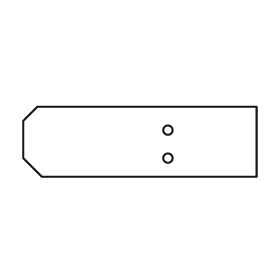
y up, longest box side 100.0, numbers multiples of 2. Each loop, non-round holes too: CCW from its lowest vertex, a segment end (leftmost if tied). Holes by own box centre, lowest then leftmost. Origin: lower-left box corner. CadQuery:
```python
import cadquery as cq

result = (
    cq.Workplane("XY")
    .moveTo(8.0, 0.0)
    .lineTo(100.0, 0.0)
    .lineTo(100.0, 30.0)
    .lineTo(6.0, 30.0)
    .lineTo(0.0, 24.0)
    .lineTo(0.0, 8.0)
    .close()
    .moveTo(62.0, 8.0)
    .circle(2.0)
    .moveTo(62.0, 20.0)
    .circle(2.0)
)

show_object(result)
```